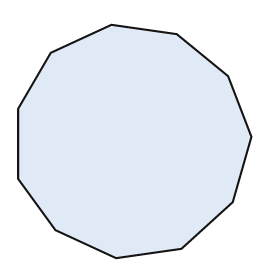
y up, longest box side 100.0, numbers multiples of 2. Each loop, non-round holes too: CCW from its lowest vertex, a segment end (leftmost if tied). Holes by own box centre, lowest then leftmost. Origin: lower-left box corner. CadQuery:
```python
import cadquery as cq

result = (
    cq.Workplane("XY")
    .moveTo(42.0, 0.0)
    .lineTo(70.0, 4.0)
    .lineTo(92.0, 24.0)
    .lineTo(100.0, 52.0)
    .lineTo(90.0, 78.0)
    .lineTo(68.0, 96.0)
    .lineTo(40.0, 100.0)
    .lineTo(14.0, 88.0)
    .lineTo(0.0, 64.0)
    .lineTo(0.0, 34.0)
    .lineTo(16.0, 12.0)
    .close()
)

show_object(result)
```